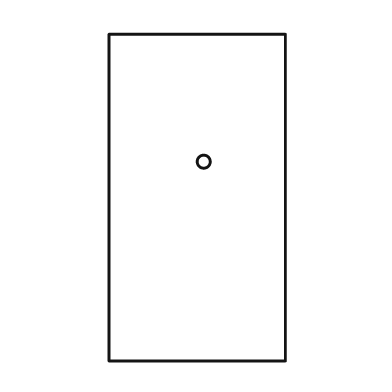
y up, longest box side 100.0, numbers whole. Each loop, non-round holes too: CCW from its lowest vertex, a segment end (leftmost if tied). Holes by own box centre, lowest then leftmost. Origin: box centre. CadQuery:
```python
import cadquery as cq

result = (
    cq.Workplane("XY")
    .moveTo(-27.0, -50.0)
    .lineTo(27.0, -50.0)
    .lineTo(27.0, 50.0)
    .lineTo(-27.0, 50.0)
    .close()
    .moveTo(2.0, 11.0)
    .circle(2.0)
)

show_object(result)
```